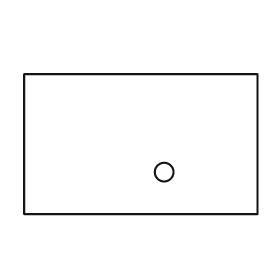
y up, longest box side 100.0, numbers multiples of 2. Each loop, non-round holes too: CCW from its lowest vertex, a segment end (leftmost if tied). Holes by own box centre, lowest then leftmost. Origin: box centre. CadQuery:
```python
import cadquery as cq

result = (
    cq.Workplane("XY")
    .moveTo(-50.0, -30.0)
    .lineTo(50.0, -30.0)
    .lineTo(50.0, 30.0)
    .lineTo(-50.0, 30.0)
    .close()
    .moveTo(10.0, -12.0)
    .circle(4.0)
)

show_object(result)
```